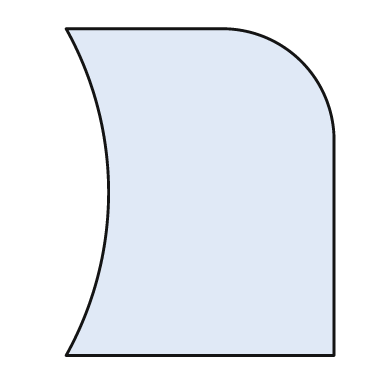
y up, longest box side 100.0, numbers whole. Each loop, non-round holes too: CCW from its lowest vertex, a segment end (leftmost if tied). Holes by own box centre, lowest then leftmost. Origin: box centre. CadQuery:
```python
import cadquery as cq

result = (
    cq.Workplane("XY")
    .moveTo(-41.0, -50.0)
    .lineTo(41.0, -50.0)
    .lineTo(41.0, 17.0)
    .threePointArc((31.0, 40.0), (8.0, 50.0))
    .lineTo(-41.0, 50.0)
    .threePointArc((-28.0, 0.0), (-41.0, -50.0))
    .close()
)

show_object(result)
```